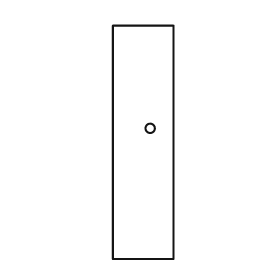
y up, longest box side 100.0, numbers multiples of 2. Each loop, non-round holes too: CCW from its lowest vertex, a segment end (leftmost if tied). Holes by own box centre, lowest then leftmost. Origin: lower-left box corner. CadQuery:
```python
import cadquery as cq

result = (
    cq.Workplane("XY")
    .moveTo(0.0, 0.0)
    .lineTo(26.0, 0.0)
    .lineTo(26.0, 100.0)
    .lineTo(0.0, 100.0)
    .close()
    .moveTo(16.0, 56.0)
    .circle(2.0)
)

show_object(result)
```